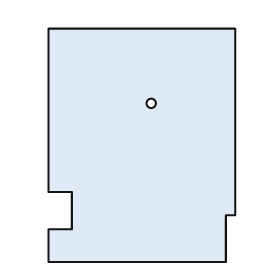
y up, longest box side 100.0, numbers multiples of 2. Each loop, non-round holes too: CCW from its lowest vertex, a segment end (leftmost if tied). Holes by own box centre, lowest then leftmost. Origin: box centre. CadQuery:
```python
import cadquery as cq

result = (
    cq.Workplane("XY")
    .moveTo(-40.0, -50.0)
    .lineTo(36.0, -50.0)
    .lineTo(36.0, -30.0)
    .lineTo(40.0, -30.0)
    .lineTo(40.0, 50.0)
    .lineTo(-40.0, 50.0)
    .lineTo(-40.0, -20.0)
    .lineTo(-30.0, -20.0)
    .lineTo(-30.0, -36.0)
    .lineTo(-40.0, -36.0)
    .close()
    .moveTo(4.0, 18.0)
    .circle(2.0)
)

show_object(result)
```